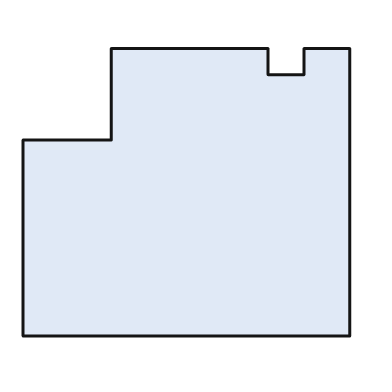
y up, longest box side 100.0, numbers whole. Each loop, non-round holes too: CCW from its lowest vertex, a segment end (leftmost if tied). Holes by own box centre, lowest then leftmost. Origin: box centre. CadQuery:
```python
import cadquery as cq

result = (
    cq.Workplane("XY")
    .moveTo(-50.0, -44.0)
    .lineTo(50.0, -44.0)
    .lineTo(50.0, 44.0)
    .lineTo(36.0, 44.0)
    .lineTo(36.0, 36.0)
    .lineTo(25.0, 36.0)
    .lineTo(25.0, 44.0)
    .lineTo(-23.0, 44.0)
    .lineTo(-23.0, 16.0)
    .lineTo(-50.0, 16.0)
    .close()
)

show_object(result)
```